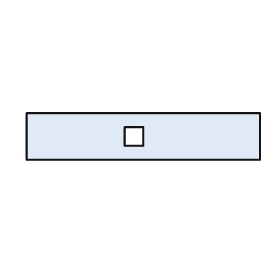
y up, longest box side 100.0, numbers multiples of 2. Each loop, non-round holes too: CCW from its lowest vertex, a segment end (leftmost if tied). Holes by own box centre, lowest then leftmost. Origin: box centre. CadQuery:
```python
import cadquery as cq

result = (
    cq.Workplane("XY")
    .moveTo(-50.0, -10.0)
    .lineTo(50.0, -10.0)
    .lineTo(50.0, 10.0)
    .lineTo(-50.0, 10.0)
    .close()
    .moveTo(-8.0, -4.0)
    .lineTo(0.0, -4.0)
    .lineTo(0.0, 4.0)
    .lineTo(-8.0, 4.0)
    .close()
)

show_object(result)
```